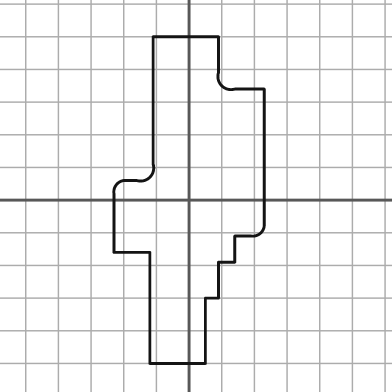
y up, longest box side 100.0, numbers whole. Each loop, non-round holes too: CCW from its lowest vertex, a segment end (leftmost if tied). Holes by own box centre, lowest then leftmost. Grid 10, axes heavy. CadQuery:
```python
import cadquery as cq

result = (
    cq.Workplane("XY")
    .moveTo(-12.0, -50.0)
    .lineTo(5.0, -50.0)
    .lineTo(5.0, -30.0)
    .lineTo(9.0, -30.0)
    .lineTo(9.0, -19.0)
    .lineTo(14.0, -19.0)
    .lineTo(14.0, -11.0)
    .lineTo(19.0, -11.0)
    .threePointArc((22.0, -10.0), (23.0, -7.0))
    .lineTo(23.0, 34.0)
    .lineTo(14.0, 34.0)
    .threePointArc((10.0, 35.0), (9.0, 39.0))
    .lineTo(9.0, 50.0)
    .lineTo(-11.0, 50.0)
    .lineTo(-11.0, 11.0)
    .threePointArc((-12.0, 7.0), (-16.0, 6.0))
    .lineTo(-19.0, 6.0)
    .threePointArc((-22.0, 5.0), (-23.0, 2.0))
    .lineTo(-23.0, -16.0)
    .lineTo(-12.0, -16.0)
    .close()
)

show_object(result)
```